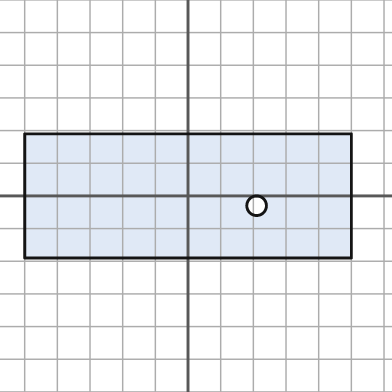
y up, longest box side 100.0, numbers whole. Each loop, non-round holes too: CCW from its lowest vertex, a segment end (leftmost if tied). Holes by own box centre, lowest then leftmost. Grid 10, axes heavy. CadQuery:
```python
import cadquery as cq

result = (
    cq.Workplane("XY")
    .moveTo(-50.0, -19.0)
    .lineTo(50.0, -19.0)
    .lineTo(50.0, 19.0)
    .lineTo(-50.0, 19.0)
    .close()
    .moveTo(21.0, -3.0)
    .circle(3.0)
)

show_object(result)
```